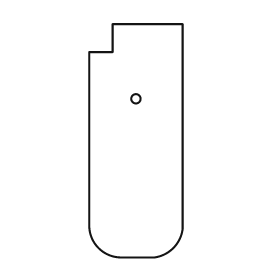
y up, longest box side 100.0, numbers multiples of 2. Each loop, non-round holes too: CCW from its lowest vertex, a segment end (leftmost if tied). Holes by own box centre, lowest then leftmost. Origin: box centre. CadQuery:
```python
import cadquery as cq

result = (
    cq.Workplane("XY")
    .moveTo(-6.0, -50.0)
    .lineTo(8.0, -50.0)
    .threePointArc((16.0, -46.0), (20.0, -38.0))
    .lineTo(20.0, 50.0)
    .lineTo(-10.0, 50.0)
    .lineTo(-10.0, 38.0)
    .lineTo(-20.0, 38.0)
    .lineTo(-20.0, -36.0)
    .threePointArc((-16.0, -46.0), (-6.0, -50.0))
    .close()
    .moveTo(0.0, 18.0)
    .circle(2.0)
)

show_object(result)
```